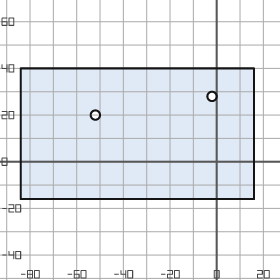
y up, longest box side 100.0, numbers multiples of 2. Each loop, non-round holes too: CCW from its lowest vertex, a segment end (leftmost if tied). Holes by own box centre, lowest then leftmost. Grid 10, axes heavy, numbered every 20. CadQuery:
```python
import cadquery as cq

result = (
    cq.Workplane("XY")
    .moveTo(-84.0, -16.0)
    .lineTo(16.0, -16.0)
    .lineTo(16.0, 40.0)
    .lineTo(-84.0, 40.0)
    .close()
    .moveTo(-52.0, 20.0)
    .circle(2.0)
    .moveTo(-2.0, 28.0)
    .circle(2.0)
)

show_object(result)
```